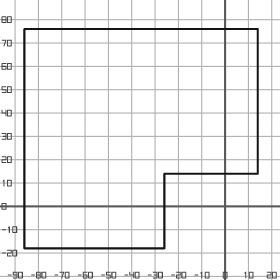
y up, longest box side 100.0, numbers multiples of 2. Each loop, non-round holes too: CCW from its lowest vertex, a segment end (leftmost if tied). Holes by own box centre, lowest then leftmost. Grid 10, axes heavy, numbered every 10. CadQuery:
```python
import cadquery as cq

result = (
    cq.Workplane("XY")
    .moveTo(-86.0, -18.0)
    .lineTo(-26.0, -18.0)
    .lineTo(-26.0, 14.0)
    .lineTo(14.0, 14.0)
    .lineTo(14.0, 76.0)
    .lineTo(-86.0, 76.0)
    .close()
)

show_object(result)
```